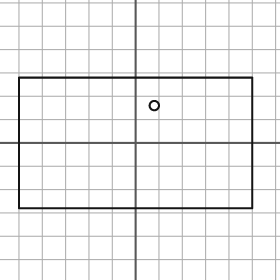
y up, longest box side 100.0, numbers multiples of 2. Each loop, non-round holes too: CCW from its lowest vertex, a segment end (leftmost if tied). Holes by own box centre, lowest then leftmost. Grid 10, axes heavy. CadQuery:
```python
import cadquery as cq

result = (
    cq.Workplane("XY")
    .moveTo(-50.0, -28.0)
    .lineTo(50.0, -28.0)
    .lineTo(50.0, 28.0)
    .lineTo(-50.0, 28.0)
    .close()
    .moveTo(8.0, 16.0)
    .circle(2.0)
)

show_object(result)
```